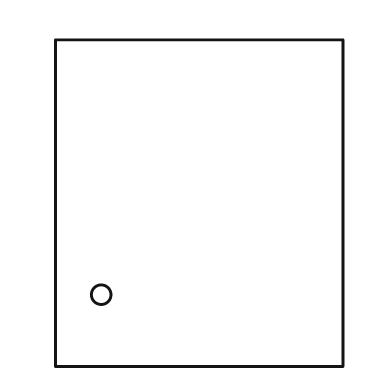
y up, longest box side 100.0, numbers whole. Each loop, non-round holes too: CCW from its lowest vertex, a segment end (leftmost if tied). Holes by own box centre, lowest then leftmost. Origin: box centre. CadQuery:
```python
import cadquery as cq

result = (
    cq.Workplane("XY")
    .moveTo(-44.0, -50.0)
    .lineTo(44.0, -50.0)
    .lineTo(44.0, 50.0)
    .lineTo(-44.0, 50.0)
    .close()
    .moveTo(-30.0, -28.0)
    .circle(3.0)
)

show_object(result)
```